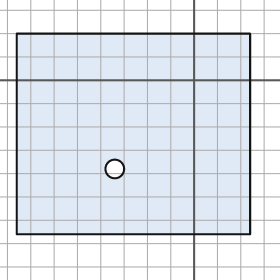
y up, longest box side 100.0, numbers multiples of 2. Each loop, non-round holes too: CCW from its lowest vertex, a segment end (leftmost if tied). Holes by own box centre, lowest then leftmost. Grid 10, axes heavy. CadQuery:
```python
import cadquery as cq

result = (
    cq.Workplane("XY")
    .moveTo(-76.0, -66.0)
    .lineTo(24.0, -66.0)
    .lineTo(24.0, 20.0)
    .lineTo(-76.0, 20.0)
    .close()
    .moveTo(-34.0, -38.0)
    .circle(4.0)
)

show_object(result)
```